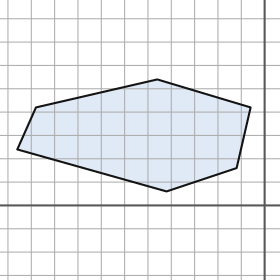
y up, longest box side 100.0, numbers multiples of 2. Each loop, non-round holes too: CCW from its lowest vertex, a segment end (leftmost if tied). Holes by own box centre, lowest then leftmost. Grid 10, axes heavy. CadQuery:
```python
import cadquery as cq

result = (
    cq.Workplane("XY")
    .moveTo(-42.0, 6.0)
    .lineTo(-12.0, 16.0)
    .lineTo(-6.0, 42.0)
    .lineTo(-46.0, 54.0)
    .lineTo(-98.0, 42.0)
    .lineTo(-106.0, 24.0)
    .close()
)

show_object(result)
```